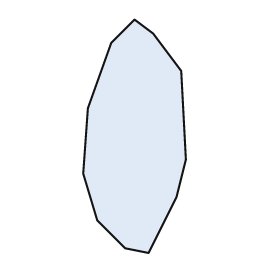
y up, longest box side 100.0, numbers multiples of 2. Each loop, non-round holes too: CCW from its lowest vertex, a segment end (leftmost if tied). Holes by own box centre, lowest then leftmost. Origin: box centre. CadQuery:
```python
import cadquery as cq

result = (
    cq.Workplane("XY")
    .moveTo(6.0, -50.0)
    .lineTo(18.0, -26.0)
    .lineTo(22.0, -10.0)
    .lineTo(20.0, 28.0)
    .lineTo(8.0, 44.0)
    .lineTo(0.0, 50.0)
    .lineTo(-10.0, 40.0)
    .lineTo(-20.0, 12.0)
    .lineTo(-22.0, -16.0)
    .lineTo(-16.0, -36.0)
    .lineTo(-4.0, -48.0)
    .close()
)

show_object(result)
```